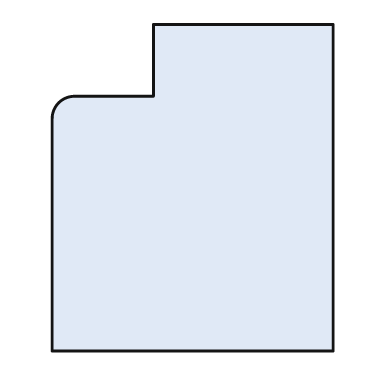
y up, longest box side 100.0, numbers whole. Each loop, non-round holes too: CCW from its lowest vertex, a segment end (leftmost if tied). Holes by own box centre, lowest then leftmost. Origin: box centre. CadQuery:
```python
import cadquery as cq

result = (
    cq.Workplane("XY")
    .moveTo(-43.0, -50.0)
    .lineTo(43.0, -50.0)
    .lineTo(43.0, 50.0)
    .lineTo(-12.0, 50.0)
    .lineTo(-12.0, 28.0)
    .lineTo(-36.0, 28.0)
    .threePointArc((-41.0, 26.0), (-43.0, 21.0))
    .close()
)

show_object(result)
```